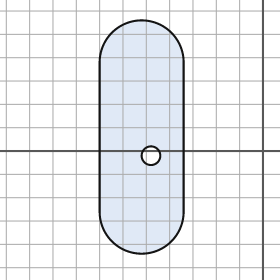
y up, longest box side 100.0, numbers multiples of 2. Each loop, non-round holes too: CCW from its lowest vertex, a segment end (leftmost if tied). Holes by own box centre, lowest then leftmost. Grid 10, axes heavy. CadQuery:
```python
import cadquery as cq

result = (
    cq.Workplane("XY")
    .moveTo(-70.0, -26.0)
    .threePointArc((-52.0, -44.0), (-34.0, -26.0))
    .lineTo(-34.0, 38.0)
    .threePointArc((-52.0, 56.0), (-70.0, 38.0))
    .close()
    .moveTo(-48.0, -2.0)
    .circle(4.0)
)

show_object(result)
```